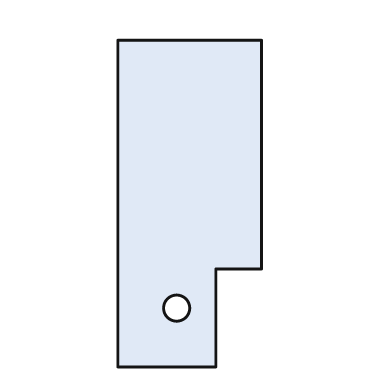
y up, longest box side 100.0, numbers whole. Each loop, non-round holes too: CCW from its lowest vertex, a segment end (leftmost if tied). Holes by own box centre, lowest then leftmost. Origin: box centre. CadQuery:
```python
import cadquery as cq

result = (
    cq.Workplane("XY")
    .moveTo(-22.0, -50.0)
    .lineTo(8.0, -50.0)
    .lineTo(8.0, -20.0)
    .lineTo(22.0, -20.0)
    .lineTo(22.0, 50.0)
    .lineTo(-22.0, 50.0)
    .close()
    .moveTo(-4.0, -32.0)
    .circle(4.0)
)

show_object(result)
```